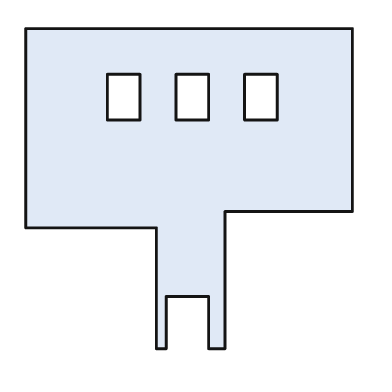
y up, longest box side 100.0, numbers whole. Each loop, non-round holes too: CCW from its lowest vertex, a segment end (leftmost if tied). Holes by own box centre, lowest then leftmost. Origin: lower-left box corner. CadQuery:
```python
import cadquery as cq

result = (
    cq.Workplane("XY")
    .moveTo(40.0, 0.0)
    .lineTo(43.0, 0.0)
    .lineTo(43.0, 16.0)
    .lineTo(56.0, 16.0)
    .lineTo(56.0, 0.0)
    .lineTo(61.0, 0.0)
    .lineTo(61.0, 42.0)
    .lineTo(100.0, 42.0)
    .lineTo(100.0, 98.0)
    .lineTo(0.0, 98.0)
    .lineTo(0.0, 37.0)
    .lineTo(40.0, 37.0)
    .close()
    .moveTo(25.0, 70.0)
    .lineTo(35.0, 70.0)
    .lineTo(35.0, 84.0)
    .lineTo(25.0, 84.0)
    .close()
    .moveTo(46.0, 70.0)
    .lineTo(56.0, 70.0)
    .lineTo(56.0, 84.0)
    .lineTo(46.0, 84.0)
    .close()
    .moveTo(67.0, 70.0)
    .lineTo(77.0, 70.0)
    .lineTo(77.0, 84.0)
    .lineTo(67.0, 84.0)
    .close()
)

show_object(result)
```